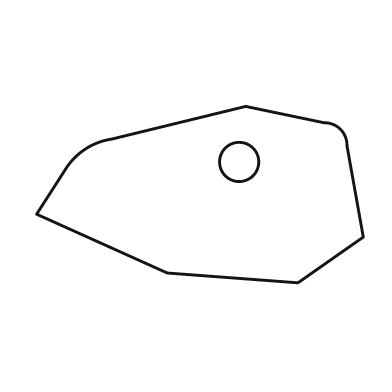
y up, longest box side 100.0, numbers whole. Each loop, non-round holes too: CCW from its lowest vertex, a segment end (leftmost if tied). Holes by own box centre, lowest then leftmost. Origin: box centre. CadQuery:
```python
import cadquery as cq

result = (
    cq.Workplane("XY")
    .moveTo(30.0, -27.0)
    .lineTo(50.0, -13.0)
    .lineTo(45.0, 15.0)
    .threePointArc((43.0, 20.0), (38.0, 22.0))
    .lineTo(14.0, 27.0)
    .lineTo(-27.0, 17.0)
    .threePointArc((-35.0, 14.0), (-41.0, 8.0))
    .lineTo(-50.0, -6.0)
    .lineTo(-10.0, -24.0)
    .close()
    .moveTo(12.0, 10.0)
    .circle(6.0)
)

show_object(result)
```